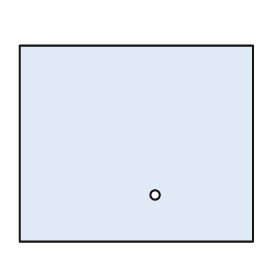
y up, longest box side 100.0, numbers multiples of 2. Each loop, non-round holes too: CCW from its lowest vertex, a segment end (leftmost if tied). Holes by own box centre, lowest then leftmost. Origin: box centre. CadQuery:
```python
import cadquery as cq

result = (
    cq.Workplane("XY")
    .moveTo(-50.0, -42.0)
    .lineTo(50.0, -42.0)
    .lineTo(50.0, 42.0)
    .lineTo(-50.0, 42.0)
    .close()
    .moveTo(8.0, -22.0)
    .circle(2.0)
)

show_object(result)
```